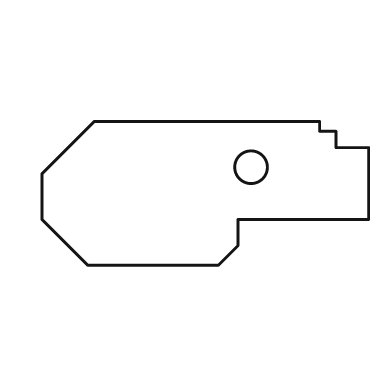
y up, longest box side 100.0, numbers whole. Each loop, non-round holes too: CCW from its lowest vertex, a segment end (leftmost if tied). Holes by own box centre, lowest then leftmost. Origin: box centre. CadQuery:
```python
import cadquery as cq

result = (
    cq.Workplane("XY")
    .moveTo(-36.0, -22.0)
    .lineTo(4.0, -22.0)
    .lineTo(10.0, -16.0)
    .lineTo(10.0, -8.0)
    .lineTo(50.0, -8.0)
    .lineTo(50.0, 14.0)
    .lineTo(40.0, 14.0)
    .lineTo(40.0, 19.0)
    .lineTo(35.0, 19.0)
    .lineTo(35.0, 22.0)
    .lineTo(-34.0, 22.0)
    .lineTo(-50.0, 6.0)
    .lineTo(-50.0, -8.0)
    .close()
    .moveTo(14.0, 8.0)
    .circle(5.0)
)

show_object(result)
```